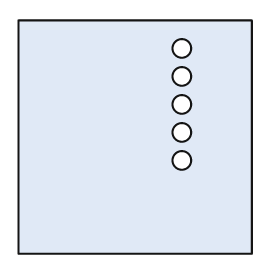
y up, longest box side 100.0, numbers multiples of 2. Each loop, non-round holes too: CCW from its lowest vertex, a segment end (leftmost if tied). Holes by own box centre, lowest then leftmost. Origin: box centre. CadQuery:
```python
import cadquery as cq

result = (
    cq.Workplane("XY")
    .moveTo(-50.0, -50.0)
    .lineTo(50.0, -50.0)
    .lineTo(50.0, 50.0)
    .lineTo(-50.0, 50.0)
    .close()
    .moveTo(20.0, -10.0)
    .circle(4.0)
    .moveTo(20.0, 2.0)
    .circle(4.0)
    .moveTo(20.0, 14.0)
    .circle(4.0)
    .moveTo(20.0, 26.0)
    .circle(4.0)
    .moveTo(20.0, 38.0)
    .circle(4.0)
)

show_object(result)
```